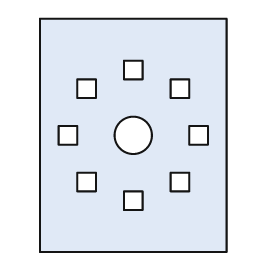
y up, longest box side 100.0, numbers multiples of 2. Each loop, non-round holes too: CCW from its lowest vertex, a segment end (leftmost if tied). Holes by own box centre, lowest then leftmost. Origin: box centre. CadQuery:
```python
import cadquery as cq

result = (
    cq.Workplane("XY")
    .moveTo(-40.0, -50.0)
    .lineTo(40.0, -50.0)
    .lineTo(40.0, 50.0)
    .lineTo(-40.0, 50.0)
    .close()
    .moveTo(-4.0, -32.0)
    .lineTo(4.0, -32.0)
    .lineTo(4.0, -24.0)
    .lineTo(-4.0, -24.0)
    .close()
    .moveTo(-24.0, -24.0)
    .lineTo(-16.0, -24.0)
    .lineTo(-16.0, -16.0)
    .lineTo(-24.0, -16.0)
    .close()
    .moveTo(16.0, -24.0)
    .lineTo(24.0, -24.0)
    .lineTo(24.0, -16.0)
    .lineTo(16.0, -16.0)
    .close()
    .moveTo(-32.0, -4.0)
    .lineTo(-24.0, -4.0)
    .lineTo(-24.0, 4.0)
    .lineTo(-32.0, 4.0)
    .close()
    .moveTo(0.0, 0.0)
    .circle(8.0)
    .moveTo(24.0, -4.0)
    .lineTo(32.0, -4.0)
    .lineTo(32.0, 4.0)
    .lineTo(24.0, 4.0)
    .close()
    .moveTo(-24.0, 16.0)
    .lineTo(-16.0, 16.0)
    .lineTo(-16.0, 24.0)
    .lineTo(-24.0, 24.0)
    .close()
    .moveTo(16.0, 16.0)
    .lineTo(24.0, 16.0)
    .lineTo(24.0, 24.0)
    .lineTo(16.0, 24.0)
    .close()
    .moveTo(-4.0, 24.0)
    .lineTo(4.0, 24.0)
    .lineTo(4.0, 32.0)
    .lineTo(-4.0, 32.0)
    .close()
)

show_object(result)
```